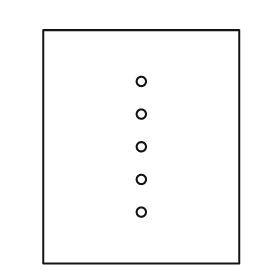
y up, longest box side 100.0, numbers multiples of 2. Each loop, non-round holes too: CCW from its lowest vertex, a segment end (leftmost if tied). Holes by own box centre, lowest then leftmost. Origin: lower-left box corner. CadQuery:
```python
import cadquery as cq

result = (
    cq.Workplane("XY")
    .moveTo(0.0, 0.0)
    .lineTo(84.0, 0.0)
    .lineTo(84.0, 100.0)
    .lineTo(0.0, 100.0)
    .close()
    .moveTo(42.0, 22.0)
    .circle(2.0)
    .moveTo(42.0, 36.0)
    .circle(2.0)
    .moveTo(42.0, 50.0)
    .circle(2.0)
    .moveTo(42.0, 64.0)
    .circle(2.0)
    .moveTo(42.0, 78.0)
    .circle(2.0)
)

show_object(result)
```